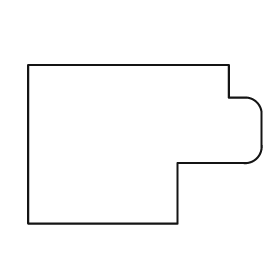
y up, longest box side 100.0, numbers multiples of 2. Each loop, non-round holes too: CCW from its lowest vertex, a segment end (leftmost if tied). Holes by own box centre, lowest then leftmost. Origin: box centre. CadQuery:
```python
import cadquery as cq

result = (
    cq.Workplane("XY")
    .moveTo(-50.0, -34.0)
    .lineTo(14.0, -34.0)
    .lineTo(14.0, -8.0)
    .lineTo(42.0, -8.0)
    .threePointArc((48.0, -6.0), (50.0, 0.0))
    .lineTo(50.0, 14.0)
    .threePointArc((48.0, 18.0), (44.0, 20.0))
    .lineTo(36.0, 20.0)
    .lineTo(36.0, 34.0)
    .lineTo(-50.0, 34.0)
    .close()
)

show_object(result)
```